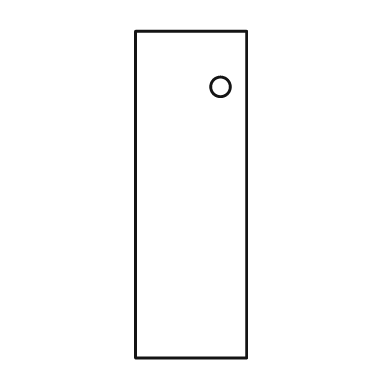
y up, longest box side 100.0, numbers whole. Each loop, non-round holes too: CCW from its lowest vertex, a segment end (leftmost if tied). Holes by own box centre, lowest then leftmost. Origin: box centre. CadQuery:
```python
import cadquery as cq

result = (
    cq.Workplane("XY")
    .moveTo(-17.0, -50.0)
    .lineTo(17.0, -50.0)
    .lineTo(17.0, 50.0)
    .lineTo(-17.0, 50.0)
    .close()
    .moveTo(9.0, 33.0)
    .circle(3.0)
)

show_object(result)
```